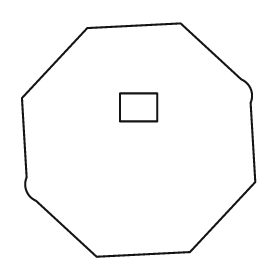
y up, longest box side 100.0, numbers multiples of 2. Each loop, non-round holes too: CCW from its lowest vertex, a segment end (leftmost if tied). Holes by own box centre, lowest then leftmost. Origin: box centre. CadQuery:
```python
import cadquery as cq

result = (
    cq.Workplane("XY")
    .moveTo(-18.0, -50.0)
    .lineTo(22.0, -48.0)
    .lineTo(50.0, -18.0)
    .lineTo(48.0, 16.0)
    .threePointArc((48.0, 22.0), (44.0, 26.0))
    .lineTo(18.0, 50.0)
    .lineTo(-22.0, 48.0)
    .lineTo(-50.0, 18.0)
    .lineTo(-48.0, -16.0)
    .threePointArc((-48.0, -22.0), (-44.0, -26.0))
    .close()
    .moveTo(-8.0, 8.0)
    .lineTo(8.0, 8.0)
    .lineTo(8.0, 20.0)
    .lineTo(-8.0, 20.0)
    .close()
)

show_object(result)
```